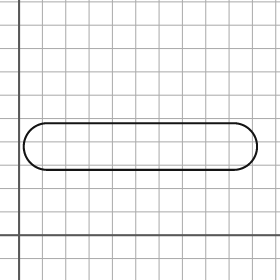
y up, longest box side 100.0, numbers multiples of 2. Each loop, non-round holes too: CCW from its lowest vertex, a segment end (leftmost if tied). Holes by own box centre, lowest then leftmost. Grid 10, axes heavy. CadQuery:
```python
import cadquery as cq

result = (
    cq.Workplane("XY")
    .moveTo(12.0, 28.0)
    .lineTo(92.0, 28.0)
    .threePointArc((102.0, 38.0), (92.0, 48.0))
    .lineTo(12.0, 48.0)
    .threePointArc((2.0, 38.0), (12.0, 28.0))
    .close()
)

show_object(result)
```